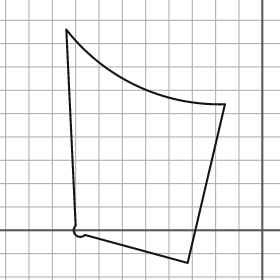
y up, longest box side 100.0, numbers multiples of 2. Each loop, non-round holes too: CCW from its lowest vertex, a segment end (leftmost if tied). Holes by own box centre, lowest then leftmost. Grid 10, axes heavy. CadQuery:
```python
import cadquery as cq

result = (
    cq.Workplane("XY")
    .moveTo(-32.0, -14.0)
    .lineTo(-16.0, 54.0)
    .threePointArc((-54.0, 62.0), (-84.0, 86.0))
    .lineTo(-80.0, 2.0)
    .threePointArc((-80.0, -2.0), (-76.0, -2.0))
    .close()
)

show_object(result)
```